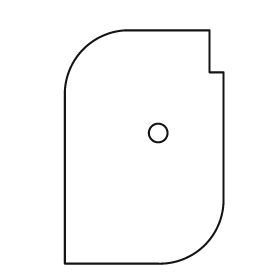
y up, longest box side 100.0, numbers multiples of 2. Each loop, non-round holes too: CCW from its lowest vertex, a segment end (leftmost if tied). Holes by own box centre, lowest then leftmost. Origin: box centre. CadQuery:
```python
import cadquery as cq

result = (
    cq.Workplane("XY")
    .moveTo(-34.0, -50.0)
    .lineTo(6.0, -50.0)
    .threePointArc((26.0, -42.0), (34.0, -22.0))
    .lineTo(34.0, 32.0)
    .lineTo(28.0, 32.0)
    .lineTo(28.0, 50.0)
    .lineTo(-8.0, 50.0)
    .threePointArc((-26.0, 42.0), (-34.0, 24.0))
    .close()
    .moveTo(6.0, 6.0)
    .circle(4.0)
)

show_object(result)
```